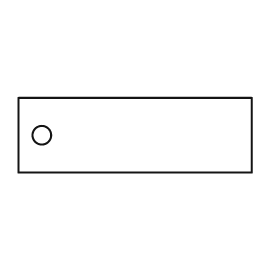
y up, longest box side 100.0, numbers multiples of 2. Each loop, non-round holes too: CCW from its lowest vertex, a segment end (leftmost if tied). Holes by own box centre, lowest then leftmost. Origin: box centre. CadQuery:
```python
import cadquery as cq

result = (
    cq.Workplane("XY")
    .moveTo(-50.0, -16.0)
    .lineTo(50.0, -16.0)
    .lineTo(50.0, 16.0)
    .lineTo(-50.0, 16.0)
    .close()
    .moveTo(-40.0, 0.0)
    .circle(4.0)
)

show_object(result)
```